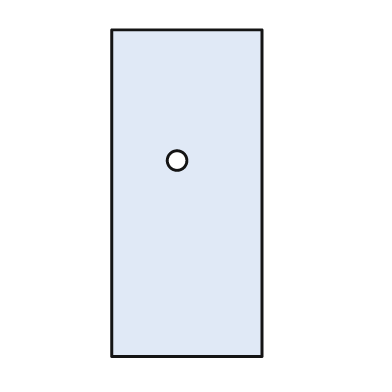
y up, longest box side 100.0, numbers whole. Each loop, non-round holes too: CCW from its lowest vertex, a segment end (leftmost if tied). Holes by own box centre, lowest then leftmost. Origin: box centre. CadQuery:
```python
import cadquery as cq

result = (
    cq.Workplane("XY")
    .moveTo(-23.0, -50.0)
    .lineTo(23.0, -50.0)
    .lineTo(23.0, 50.0)
    .lineTo(-23.0, 50.0)
    .close()
    .moveTo(-3.0, 10.0)
    .circle(3.0)
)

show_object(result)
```